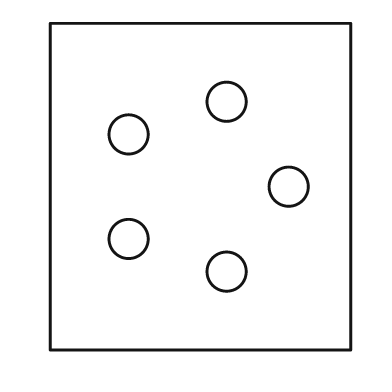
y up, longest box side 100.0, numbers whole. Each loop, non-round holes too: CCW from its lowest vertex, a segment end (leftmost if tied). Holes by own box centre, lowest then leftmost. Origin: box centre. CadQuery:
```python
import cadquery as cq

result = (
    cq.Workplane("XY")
    .moveTo(-46.0, -50.0)
    .lineTo(46.0, -50.0)
    .lineTo(46.0, 50.0)
    .lineTo(-46.0, 50.0)
    .close()
    .moveTo(8.0, -26.0)
    .circle(6.0)
    .moveTo(-22.0, -16.0)
    .circle(6.0)
    .moveTo(27.0, 0.0)
    .circle(6.0)
    .moveTo(-22.0, 16.0)
    .circle(6.0)
    .moveTo(8.0, 26.0)
    .circle(6.0)
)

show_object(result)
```